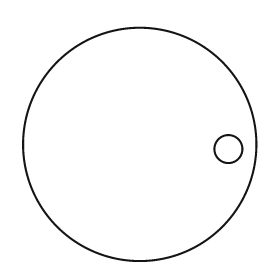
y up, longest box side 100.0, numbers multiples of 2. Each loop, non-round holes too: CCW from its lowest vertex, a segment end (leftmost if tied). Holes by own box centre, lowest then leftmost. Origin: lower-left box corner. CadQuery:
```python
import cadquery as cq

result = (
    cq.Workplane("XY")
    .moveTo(50.0, 50.0)
    .circle(50.0)
    .moveTo(88.0, 48.0)
    .circle(6.0)
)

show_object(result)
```